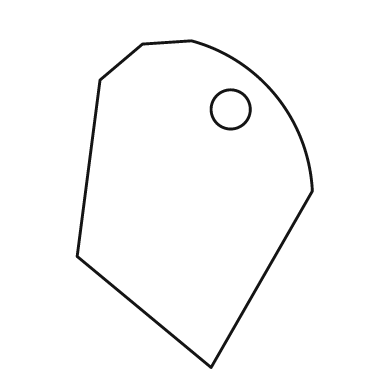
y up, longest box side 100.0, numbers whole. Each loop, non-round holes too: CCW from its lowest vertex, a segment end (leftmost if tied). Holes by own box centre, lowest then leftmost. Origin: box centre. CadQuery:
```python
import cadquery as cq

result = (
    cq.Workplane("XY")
    .moveTo(5.0, -50.0)
    .lineTo(36.0, 4.0)
    .threePointArc((25.0, 33.0), (-1.0, 50.0))
    .lineTo(-16.0, 49.0)
    .lineTo(-29.0, 38.0)
    .lineTo(-36.0, -16.0)
    .close()
    .moveTo(11.0, 29.0)
    .circle(6.0)
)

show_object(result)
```